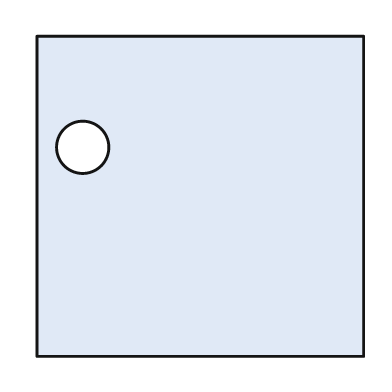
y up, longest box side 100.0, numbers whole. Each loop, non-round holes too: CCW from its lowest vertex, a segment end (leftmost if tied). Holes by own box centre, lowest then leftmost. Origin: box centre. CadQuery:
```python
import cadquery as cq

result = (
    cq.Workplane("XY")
    .moveTo(-50.0, -49.0)
    .lineTo(50.0, -49.0)
    .lineTo(50.0, 49.0)
    .lineTo(-50.0, 49.0)
    .close()
    .moveTo(-36.0, 15.0)
    .circle(8.0)
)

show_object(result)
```